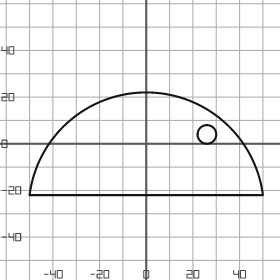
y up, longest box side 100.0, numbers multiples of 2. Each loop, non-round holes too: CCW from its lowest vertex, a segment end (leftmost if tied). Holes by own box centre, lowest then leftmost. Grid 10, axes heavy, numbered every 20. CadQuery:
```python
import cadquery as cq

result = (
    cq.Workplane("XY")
    .moveTo(-50.0, -22.0)
    .lineTo(50.0, -22.0)
    .threePointArc((0.0, 22.0), (-50.0, -22.0))
    .close()
    .moveTo(26.0, 4.0)
    .circle(4.0)
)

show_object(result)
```